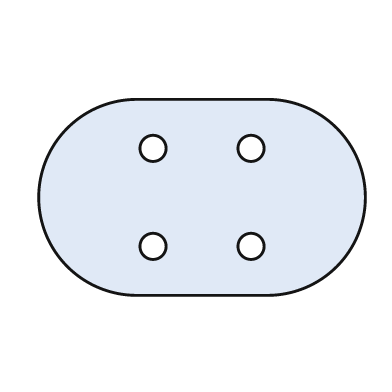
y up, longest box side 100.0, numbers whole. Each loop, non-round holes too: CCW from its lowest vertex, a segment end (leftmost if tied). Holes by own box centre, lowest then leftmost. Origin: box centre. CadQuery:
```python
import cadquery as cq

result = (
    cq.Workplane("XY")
    .moveTo(-20.0, -30.0)
    .lineTo(20.0, -30.0)
    .threePointArc((50.0, 0.0), (20.0, 30.0))
    .lineTo(-20.0, 30.0)
    .threePointArc((-50.0, 0.0), (-20.0, -30.0))
    .close()
    .moveTo(-15.0, -15.0)
    .circle(4.0)
    .moveTo(15.0, -15.0)
    .circle(4.0)
    .moveTo(-15.0, 15.0)
    .circle(4.0)
    .moveTo(15.0, 15.0)
    .circle(4.0)
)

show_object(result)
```